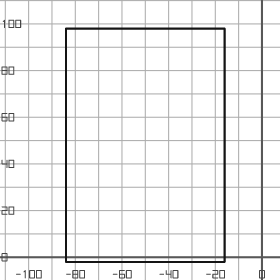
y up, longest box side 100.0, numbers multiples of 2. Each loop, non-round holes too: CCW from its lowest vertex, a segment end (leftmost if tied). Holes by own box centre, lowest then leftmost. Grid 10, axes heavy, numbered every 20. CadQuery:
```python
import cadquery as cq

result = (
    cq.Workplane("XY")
    .moveTo(-84.0, -2.0)
    .lineTo(-16.0, -2.0)
    .lineTo(-16.0, 98.0)
    .lineTo(-84.0, 98.0)
    .close()
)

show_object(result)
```